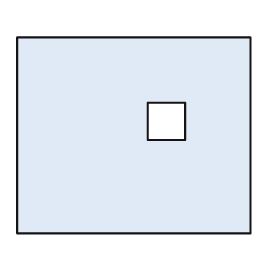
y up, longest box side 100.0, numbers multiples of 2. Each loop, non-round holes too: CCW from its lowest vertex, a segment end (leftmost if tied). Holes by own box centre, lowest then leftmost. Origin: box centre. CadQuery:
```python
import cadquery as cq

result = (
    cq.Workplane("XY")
    .moveTo(-50.0, -42.0)
    .lineTo(50.0, -42.0)
    .lineTo(50.0, 42.0)
    .lineTo(-50.0, 42.0)
    .close()
    .moveTo(6.0, -2.0)
    .lineTo(22.0, -2.0)
    .lineTo(22.0, 14.0)
    .lineTo(6.0, 14.0)
    .close()
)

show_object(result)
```